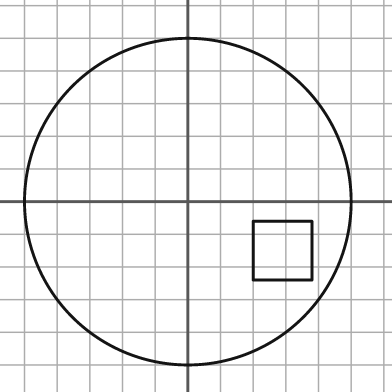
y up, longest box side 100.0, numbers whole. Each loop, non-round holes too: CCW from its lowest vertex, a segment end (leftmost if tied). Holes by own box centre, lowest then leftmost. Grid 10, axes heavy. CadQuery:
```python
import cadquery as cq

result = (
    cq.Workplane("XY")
    .moveTo(0.0, 0.0)
    .circle(50.0)
    .moveTo(20.0, -24.0)
    .lineTo(38.0, -24.0)
    .lineTo(38.0, -6.0)
    .lineTo(20.0, -6.0)
    .close()
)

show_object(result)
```